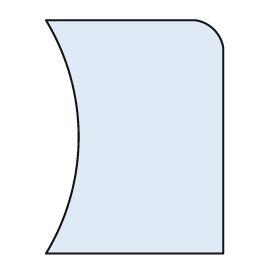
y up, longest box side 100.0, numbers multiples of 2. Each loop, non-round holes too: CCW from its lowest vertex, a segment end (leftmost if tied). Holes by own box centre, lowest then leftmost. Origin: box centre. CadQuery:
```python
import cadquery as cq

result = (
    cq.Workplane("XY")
    .moveTo(-38.0, -50.0)
    .lineTo(38.0, -50.0)
    .lineTo(38.0, 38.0)
    .threePointArc((34.0, 46.0), (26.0, 50.0))
    .lineTo(-38.0, 50.0)
    .threePointArc((-24.0, 0.0), (-38.0, -50.0))
    .close()
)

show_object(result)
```